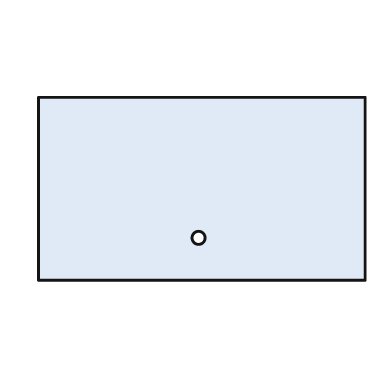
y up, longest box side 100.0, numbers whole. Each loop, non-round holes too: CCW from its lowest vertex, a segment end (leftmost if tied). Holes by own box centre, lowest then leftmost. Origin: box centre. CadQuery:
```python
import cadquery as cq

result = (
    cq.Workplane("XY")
    .moveTo(-50.0, -28.0)
    .lineTo(50.0, -28.0)
    .lineTo(50.0, 28.0)
    .lineTo(-50.0, 28.0)
    .close()
    .moveTo(-1.0, -15.0)
    .circle(2.0)
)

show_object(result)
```